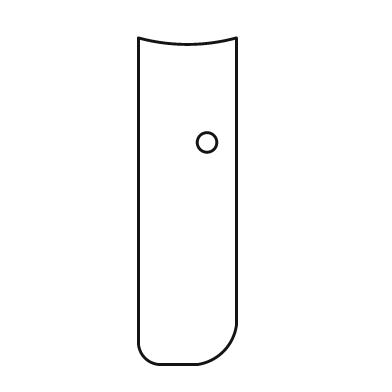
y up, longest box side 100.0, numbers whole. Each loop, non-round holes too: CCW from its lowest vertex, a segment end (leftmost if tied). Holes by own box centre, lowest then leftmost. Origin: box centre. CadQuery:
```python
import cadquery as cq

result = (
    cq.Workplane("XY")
    .moveTo(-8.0, -50.0)
    .lineTo(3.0, -50.0)
    .threePointArc((11.0, -46.0), (15.0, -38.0))
    .lineTo(15.0, 50.0)
    .threePointArc((0.0, 48.0), (-15.0, 50.0))
    .lineTo(-15.0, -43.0)
    .threePointArc((-13.0, -48.0), (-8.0, -50.0))
    .close()
    .moveTo(6.0, 18.0)
    .circle(3.0)
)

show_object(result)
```